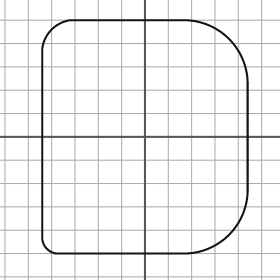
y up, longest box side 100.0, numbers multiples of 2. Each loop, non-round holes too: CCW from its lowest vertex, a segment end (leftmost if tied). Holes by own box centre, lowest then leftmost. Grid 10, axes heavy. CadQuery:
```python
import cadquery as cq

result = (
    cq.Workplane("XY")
    .moveTo(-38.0, -50.0)
    .lineTo(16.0, -50.0)
    .threePointArc((36.0, -42.0), (44.0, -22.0))
    .lineTo(44.0, 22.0)
    .threePointArc((36.0, 42.0), (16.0, 50.0))
    .lineTo(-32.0, 50.0)
    .threePointArc((-40.0, 46.0), (-44.0, 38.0))
    .lineTo(-44.0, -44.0)
    .threePointArc((-42.0, -48.0), (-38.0, -50.0))
    .close()
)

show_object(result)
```